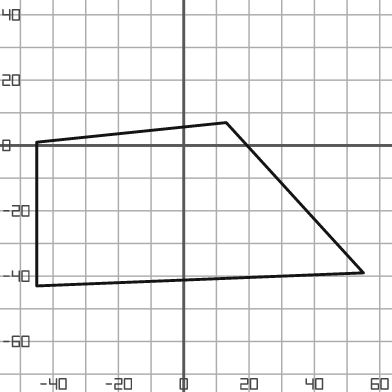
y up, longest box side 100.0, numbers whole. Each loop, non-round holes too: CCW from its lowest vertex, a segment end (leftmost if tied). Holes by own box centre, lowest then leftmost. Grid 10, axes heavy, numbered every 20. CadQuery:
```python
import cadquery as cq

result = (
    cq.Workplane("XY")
    .moveTo(-45.0, -43.0)
    .lineTo(55.0, -39.0)
    .lineTo(13.0, 7.0)
    .lineTo(-45.0, 1.0)
    .close()
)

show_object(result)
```